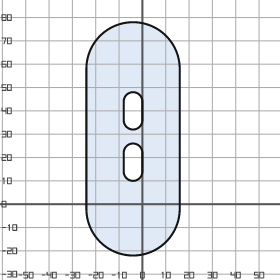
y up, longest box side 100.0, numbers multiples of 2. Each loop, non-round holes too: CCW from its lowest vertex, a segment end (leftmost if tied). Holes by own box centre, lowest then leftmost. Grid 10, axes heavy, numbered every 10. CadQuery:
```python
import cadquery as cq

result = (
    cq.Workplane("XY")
    .moveTo(-24.0, -2.0)
    .threePointArc((-4.0, -22.0), (16.0, -2.0))
    .lineTo(16.0, 58.0)
    .threePointArc((-4.0, 78.0), (-24.0, 58.0))
    .close()
    .moveTo(-8.0, 14.0)
    .threePointArc((-4.0, 10.0), (0.0, 14.0))
    .lineTo(0.0, 22.0)
    .threePointArc((-4.0, 26.0), (-8.0, 22.0))
    .close()
    .moveTo(-8.0, 36.0)
    .threePointArc((-4.0, 32.0), (0.0, 36.0))
    .lineTo(0.0, 44.0)
    .threePointArc((-4.0, 48.0), (-8.0, 44.0))
    .close()
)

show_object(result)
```